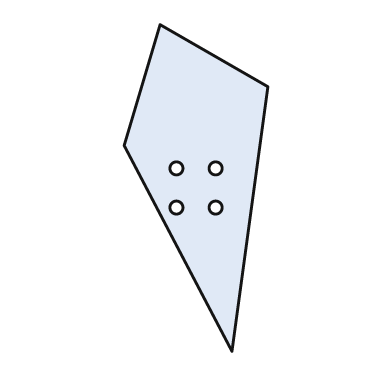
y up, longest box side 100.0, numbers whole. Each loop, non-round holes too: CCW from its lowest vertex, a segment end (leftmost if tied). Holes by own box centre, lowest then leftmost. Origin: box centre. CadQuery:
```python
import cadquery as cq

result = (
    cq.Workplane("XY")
    .moveTo(11.0, -50.0)
    .lineTo(22.0, 31.0)
    .lineTo(-11.0, 50.0)
    .lineTo(-22.0, 13.0)
    .close()
    .moveTo(-6.0, -6.0)
    .circle(2.0)
    .moveTo(6.0, -6.0)
    .circle(2.0)
    .moveTo(-6.0, 6.0)
    .circle(2.0)
    .moveTo(6.0, 6.0)
    .circle(2.0)
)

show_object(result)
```